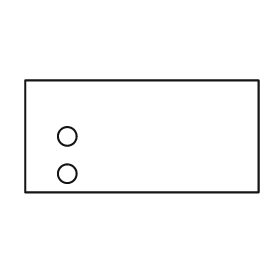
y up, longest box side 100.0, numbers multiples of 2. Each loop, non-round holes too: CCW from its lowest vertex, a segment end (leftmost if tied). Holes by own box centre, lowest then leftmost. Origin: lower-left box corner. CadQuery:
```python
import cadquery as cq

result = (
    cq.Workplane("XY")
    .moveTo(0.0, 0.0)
    .lineTo(100.0, 0.0)
    .lineTo(100.0, 48.0)
    .lineTo(0.0, 48.0)
    .close()
    .moveTo(18.0, 8.0)
    .circle(4.0)
    .moveTo(18.0, 24.0)
    .circle(4.0)
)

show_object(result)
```